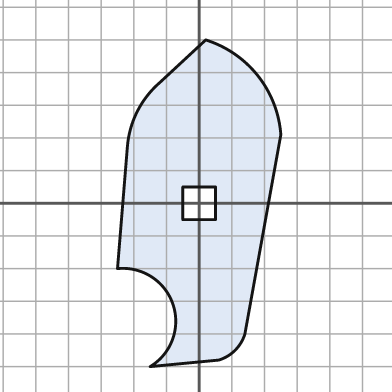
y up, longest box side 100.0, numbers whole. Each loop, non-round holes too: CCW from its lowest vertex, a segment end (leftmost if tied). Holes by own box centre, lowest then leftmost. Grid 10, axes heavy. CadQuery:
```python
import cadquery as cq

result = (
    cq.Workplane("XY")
    .moveTo(-15.0, -50.0)
    .lineTo(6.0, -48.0)
    .threePointArc((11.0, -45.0), (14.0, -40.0))
    .lineTo(25.0, 21.0)
    .threePointArc((18.0, 39.0), (2.0, 50.0))
    .lineTo(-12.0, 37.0)
    .threePointArc((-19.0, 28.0), (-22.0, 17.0))
    .lineTo(-25.0, -20.0)
    .threePointArc((-8.0, -31.0), (-15.0, -50.0))
    .close()
    .moveTo(-5.0, -5.0)
    .lineTo(5.0, -5.0)
    .lineTo(5.0, 5.0)
    .lineTo(-5.0, 5.0)
    .close()
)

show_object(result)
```